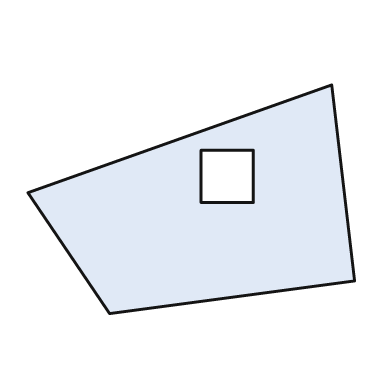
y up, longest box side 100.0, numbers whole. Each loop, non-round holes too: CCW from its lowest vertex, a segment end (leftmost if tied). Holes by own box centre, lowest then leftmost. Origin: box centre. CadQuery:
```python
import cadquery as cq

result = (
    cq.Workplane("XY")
    .moveTo(-25.0, -35.0)
    .lineTo(50.0, -25.0)
    .lineTo(43.0, 35.0)
    .lineTo(-50.0, 2.0)
    .close()
    .moveTo(3.0, -1.0)
    .lineTo(19.0, -1.0)
    .lineTo(19.0, 15.0)
    .lineTo(3.0, 15.0)
    .close()
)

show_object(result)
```